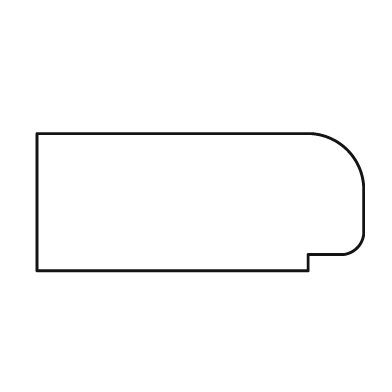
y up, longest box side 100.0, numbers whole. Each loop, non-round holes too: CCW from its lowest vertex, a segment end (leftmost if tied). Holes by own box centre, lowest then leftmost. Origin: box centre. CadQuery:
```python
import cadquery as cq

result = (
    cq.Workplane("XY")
    .moveTo(-50.0, -21.0)
    .lineTo(33.0, -21.0)
    .lineTo(33.0, -16.0)
    .lineTo(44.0, -16.0)
    .threePointArc((48.0, -14.0), (50.0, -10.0))
    .lineTo(50.0, 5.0)
    .threePointArc((45.0, 16.0), (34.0, 21.0))
    .lineTo(-50.0, 21.0)
    .close()
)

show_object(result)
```